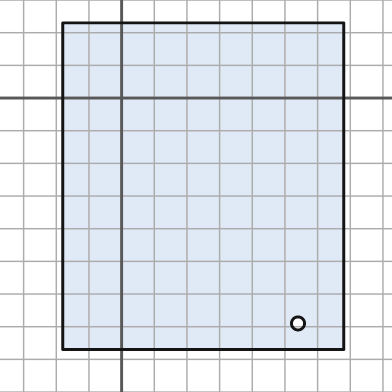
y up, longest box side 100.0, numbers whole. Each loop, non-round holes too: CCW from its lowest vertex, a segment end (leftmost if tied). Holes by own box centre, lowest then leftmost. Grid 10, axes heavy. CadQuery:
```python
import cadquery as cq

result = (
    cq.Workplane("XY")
    .moveTo(-18.0, -77.0)
    .lineTo(68.0, -77.0)
    .lineTo(68.0, 23.0)
    .lineTo(-18.0, 23.0)
    .close()
    .moveTo(54.0, -69.0)
    .circle(2.0)
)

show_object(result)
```